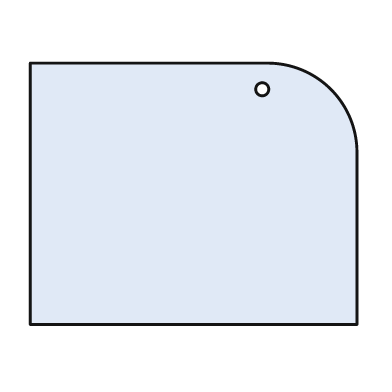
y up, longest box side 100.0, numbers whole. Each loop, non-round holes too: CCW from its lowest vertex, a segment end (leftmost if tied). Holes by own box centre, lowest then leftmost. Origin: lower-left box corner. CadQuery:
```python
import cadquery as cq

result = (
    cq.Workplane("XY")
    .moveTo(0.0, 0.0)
    .lineTo(100.0, 0.0)
    .lineTo(100.0, 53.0)
    .threePointArc((92.0, 72.0), (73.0, 80.0))
    .lineTo(0.0, 80.0)
    .close()
    .moveTo(71.0, 72.0)
    .circle(2.0)
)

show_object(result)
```